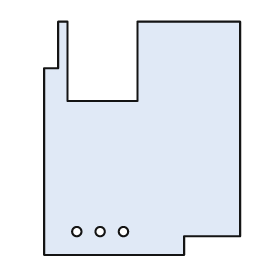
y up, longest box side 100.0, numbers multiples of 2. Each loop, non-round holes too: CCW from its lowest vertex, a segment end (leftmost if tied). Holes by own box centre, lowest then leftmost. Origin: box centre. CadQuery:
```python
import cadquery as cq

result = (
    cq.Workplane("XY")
    .moveTo(-42.0, -50.0)
    .lineTo(18.0, -50.0)
    .lineTo(18.0, -42.0)
    .lineTo(42.0, -42.0)
    .lineTo(42.0, 50.0)
    .lineTo(-2.0, 50.0)
    .lineTo(-2.0, 16.0)
    .lineTo(-32.0, 16.0)
    .lineTo(-32.0, 50.0)
    .lineTo(-36.0, 50.0)
    .lineTo(-36.0, 30.0)
    .lineTo(-42.0, 30.0)
    .close()
    .moveTo(-28.0, -40.0)
    .circle(2.0)
    .moveTo(-18.0, -40.0)
    .circle(2.0)
    .moveTo(-8.0, -40.0)
    .circle(2.0)
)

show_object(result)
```